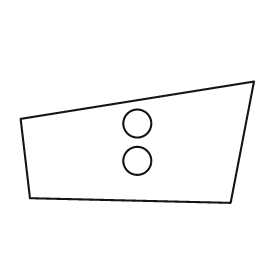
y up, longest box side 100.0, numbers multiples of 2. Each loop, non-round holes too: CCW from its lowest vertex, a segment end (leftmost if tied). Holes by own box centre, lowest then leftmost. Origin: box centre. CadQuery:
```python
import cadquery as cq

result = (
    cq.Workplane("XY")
    .moveTo(40.0, -26.0)
    .lineTo(50.0, 26.0)
    .lineTo(-50.0, 10.0)
    .lineTo(-46.0, -24.0)
    .close()
    .moveTo(0.0, -8.0)
    .circle(6.0)
    .moveTo(0.0, 8.0)
    .circle(6.0)
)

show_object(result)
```